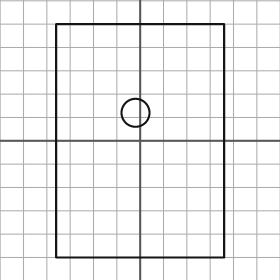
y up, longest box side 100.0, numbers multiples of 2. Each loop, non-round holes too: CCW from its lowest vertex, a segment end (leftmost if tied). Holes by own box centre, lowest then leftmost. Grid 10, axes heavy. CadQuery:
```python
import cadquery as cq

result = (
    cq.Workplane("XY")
    .moveTo(-36.0, -50.0)
    .lineTo(36.0, -50.0)
    .lineTo(36.0, 50.0)
    .lineTo(-36.0, 50.0)
    .close()
    .moveTo(-2.0, 12.0)
    .circle(6.0)
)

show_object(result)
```